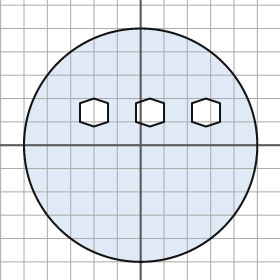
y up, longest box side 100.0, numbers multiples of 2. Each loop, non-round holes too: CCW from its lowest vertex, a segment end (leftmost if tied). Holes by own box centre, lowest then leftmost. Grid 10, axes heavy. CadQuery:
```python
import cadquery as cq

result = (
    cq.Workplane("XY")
    .moveTo(0.0, 0.0)
    .circle(50.0)
    .moveTo(-20.0, 8.0)
    .lineTo(-14.0, 10.0)
    .lineTo(-14.0, 18.0)
    .lineTo(-20.0, 20.0)
    .lineTo(-26.0, 18.0)
    .lineTo(-26.0, 10.0)
    .close()
    .moveTo(4.0, 8.0)
    .lineTo(10.0, 10.0)
    .lineTo(10.0, 18.0)
    .lineTo(4.0, 20.0)
    .lineTo(-2.0, 18.0)
    .lineTo(-2.0, 10.0)
    .close()
    .moveTo(28.0, 8.0)
    .lineTo(34.0, 10.0)
    .lineTo(34.0, 18.0)
    .lineTo(28.0, 20.0)
    .lineTo(22.0, 18.0)
    .lineTo(22.0, 10.0)
    .close()
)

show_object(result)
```